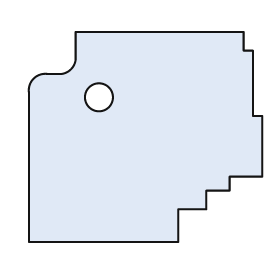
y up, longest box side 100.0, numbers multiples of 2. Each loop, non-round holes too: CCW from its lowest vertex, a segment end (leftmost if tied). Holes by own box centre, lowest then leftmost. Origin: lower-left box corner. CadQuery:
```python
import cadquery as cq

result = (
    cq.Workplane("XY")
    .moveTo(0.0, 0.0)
    .lineTo(64.0, 0.0)
    .lineTo(64.0, 14.0)
    .lineTo(76.0, 14.0)
    .lineTo(76.0, 22.0)
    .lineTo(86.0, 22.0)
    .lineTo(86.0, 28.0)
    .lineTo(100.0, 28.0)
    .lineTo(100.0, 54.0)
    .lineTo(96.0, 54.0)
    .lineTo(96.0, 82.0)
    .lineTo(92.0, 82.0)
    .lineTo(92.0, 90.0)
    .lineTo(20.0, 90.0)
    .lineTo(20.0, 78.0)
    .threePointArc((18.0, 74.0), (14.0, 72.0))
    .lineTo(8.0, 72.0)
    .threePointArc((2.0, 70.0), (0.0, 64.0))
    .close()
    .moveTo(30.0, 62.0)
    .circle(6.0)
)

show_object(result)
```